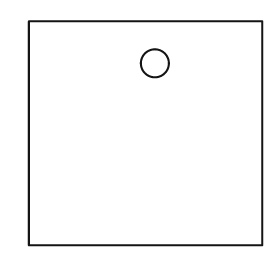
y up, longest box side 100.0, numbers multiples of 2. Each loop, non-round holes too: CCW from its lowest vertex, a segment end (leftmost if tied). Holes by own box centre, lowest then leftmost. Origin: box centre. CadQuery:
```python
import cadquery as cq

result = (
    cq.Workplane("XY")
    .moveTo(-50.0, -48.0)
    .lineTo(50.0, -48.0)
    .lineTo(50.0, 48.0)
    .lineTo(-50.0, 48.0)
    .close()
    .moveTo(4.0, 30.0)
    .circle(6.0)
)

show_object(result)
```